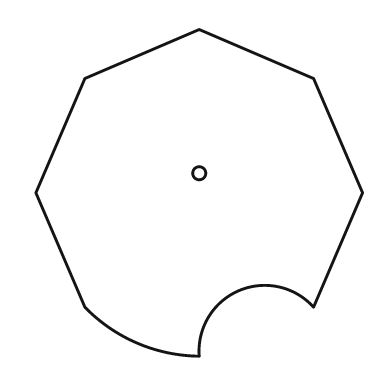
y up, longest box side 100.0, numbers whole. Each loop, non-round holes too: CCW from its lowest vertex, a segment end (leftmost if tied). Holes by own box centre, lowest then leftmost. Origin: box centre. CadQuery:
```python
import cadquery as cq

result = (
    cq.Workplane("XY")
    .moveTo(0.0, -50.0)
    .threePointArc((12.0, -30.0), (35.0, -35.0))
    .lineTo(50.0, 0.0)
    .lineTo(35.0, 35.0)
    .lineTo(0.0, 50.0)
    .lineTo(-35.0, 35.0)
    .lineTo(-50.0, 0.0)
    .lineTo(-35.0, -35.0)
    .threePointArc((-19.0, -46.0), (0.0, -50.0))
    .close()
    .moveTo(0.0, 6.0)
    .circle(2.0)
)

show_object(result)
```